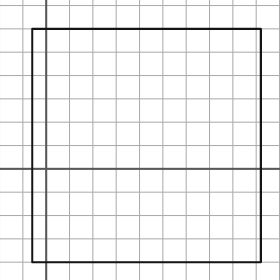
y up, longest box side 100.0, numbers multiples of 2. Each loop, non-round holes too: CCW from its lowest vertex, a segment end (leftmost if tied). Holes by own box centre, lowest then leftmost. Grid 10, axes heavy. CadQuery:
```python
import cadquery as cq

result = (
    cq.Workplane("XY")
    .moveTo(-6.0, -40.0)
    .lineTo(92.0, -40.0)
    .lineTo(92.0, 60.0)
    .lineTo(-6.0, 60.0)
    .close()
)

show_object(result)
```